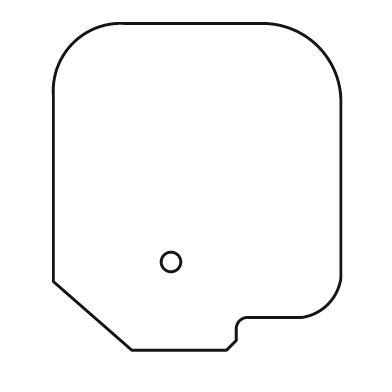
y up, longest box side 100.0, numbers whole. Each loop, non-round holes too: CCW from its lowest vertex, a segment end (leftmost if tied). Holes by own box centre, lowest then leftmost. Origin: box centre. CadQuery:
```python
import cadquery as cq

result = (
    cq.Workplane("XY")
    .moveTo(-20.0, -50.0)
    .lineTo(9.0, -50.0)
    .lineTo(12.0, -47.0)
    .lineTo(12.0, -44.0)
    .threePointArc((13.0, -41.0), (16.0, -40.0))
    .lineTo(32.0, -40.0)
    .threePointArc((40.0, -36.0), (44.0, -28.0))
    .lineTo(44.0, 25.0)
    .threePointArc((37.0, 43.0), (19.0, 50.0))
    .lineTo(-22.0, 50.0)
    .threePointArc((-38.0, 44.0), (-44.0, 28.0))
    .lineTo(-44.0, -29.0)
    .close()
    .moveTo(-8.0, -23.0)
    .circle(3.0)
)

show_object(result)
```